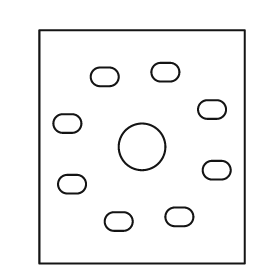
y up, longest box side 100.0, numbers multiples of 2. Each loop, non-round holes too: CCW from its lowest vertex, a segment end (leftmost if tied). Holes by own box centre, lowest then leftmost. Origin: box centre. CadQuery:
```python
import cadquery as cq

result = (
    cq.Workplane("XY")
    .moveTo(-44.0, -50.0)
    .lineTo(44.0, -50.0)
    .lineTo(44.0, 50.0)
    .lineTo(-44.0, 50.0)
    .close()
    .moveTo(-12.0, -36.0)
    .lineTo(-8.0, -36.0)
    .threePointArc((-4.0, -32.0), (-8.0, -28.0))
    .lineTo(-12.0, -28.0)
    .threePointArc((-16.0, -32.0), (-12.0, -36.0))
    .close()
    .moveTo(14.0, -34.0)
    .lineTo(18.0, -34.0)
    .threePointArc((22.0, -30.0), (18.0, -26.0))
    .lineTo(14.0, -26.0)
    .threePointArc((10.0, -30.0), (14.0, -34.0))
    .close()
    .moveTo(-32.0, -20.0)
    .lineTo(-28.0, -20.0)
    .threePointArc((-24.0, -16.0), (-28.0, -12.0))
    .lineTo(-32.0, -12.0)
    .threePointArc((-36.0, -16.0), (-32.0, -20.0))
    .close()
    .moveTo(30.0, -14.0)
    .lineTo(34.0, -14.0)
    .threePointArc((38.0, -10.0), (34.0, -6.0))
    .lineTo(30.0, -6.0)
    .threePointArc((26.0, -10.0), (30.0, -14.0))
    .close()
    .moveTo(0.0, 0.0)
    .circle(10.0)
    .moveTo(-34.0, 6.0)
    .lineTo(-30.0, 6.0)
    .threePointArc((-26.0, 10.0), (-30.0, 14.0))
    .lineTo(-34.0, 14.0)
    .threePointArc((-38.0, 10.0), (-34.0, 6.0))
    .close()
    .moveTo(28.0, 12.0)
    .lineTo(32.0, 12.0)
    .threePointArc((36.0, 16.0), (32.0, 20.0))
    .lineTo(28.0, 20.0)
    .threePointArc((24.0, 16.0), (28.0, 12.0))
    .close()
    .moveTo(-18.0, 26.0)
    .lineTo(-14.0, 26.0)
    .threePointArc((-10.0, 30.0), (-14.0, 34.0))
    .lineTo(-18.0, 34.0)
    .threePointArc((-22.0, 30.0), (-18.0, 26.0))
    .close()
    .moveTo(8.0, 28.0)
    .lineTo(12.0, 28.0)
    .threePointArc((16.0, 32.0), (12.0, 36.0))
    .lineTo(8.0, 36.0)
    .threePointArc((4.0, 32.0), (8.0, 28.0))
    .close()
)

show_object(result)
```